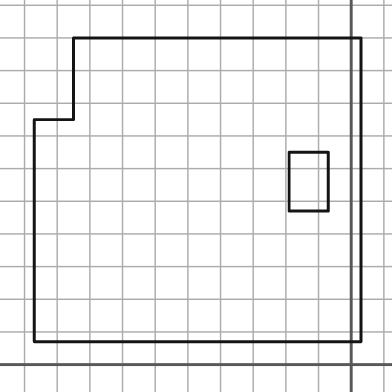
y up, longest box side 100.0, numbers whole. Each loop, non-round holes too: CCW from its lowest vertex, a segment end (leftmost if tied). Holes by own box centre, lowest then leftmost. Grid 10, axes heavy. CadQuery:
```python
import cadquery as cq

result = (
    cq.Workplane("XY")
    .moveTo(-97.0, 7.0)
    .lineTo(3.0, 7.0)
    .lineTo(3.0, 100.0)
    .lineTo(-85.0, 100.0)
    .lineTo(-85.0, 75.0)
    .lineTo(-97.0, 75.0)
    .close()
    .moveTo(-19.0, 47.0)
    .lineTo(-7.0, 47.0)
    .lineTo(-7.0, 65.0)
    .lineTo(-19.0, 65.0)
    .close()
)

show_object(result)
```